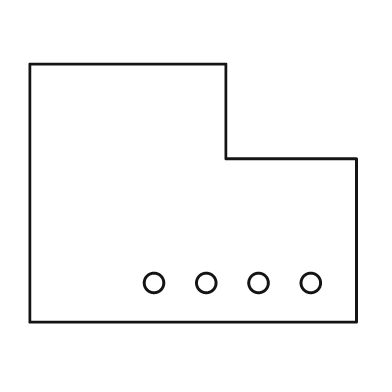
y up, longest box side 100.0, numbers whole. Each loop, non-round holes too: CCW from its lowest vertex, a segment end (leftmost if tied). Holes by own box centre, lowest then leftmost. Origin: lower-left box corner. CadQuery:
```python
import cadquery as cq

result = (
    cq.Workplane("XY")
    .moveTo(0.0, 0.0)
    .lineTo(100.0, 0.0)
    .lineTo(100.0, 50.0)
    .lineTo(60.0, 50.0)
    .lineTo(60.0, 79.0)
    .lineTo(0.0, 79.0)
    .close()
    .moveTo(38.0, 12.0)
    .circle(3.0)
    .moveTo(54.0, 12.0)
    .circle(3.0)
    .moveTo(70.0, 12.0)
    .circle(3.0)
    .moveTo(86.0, 12.0)
    .circle(3.0)
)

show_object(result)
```